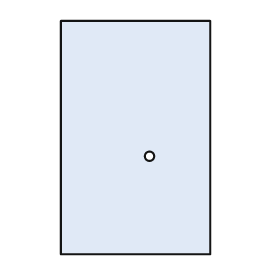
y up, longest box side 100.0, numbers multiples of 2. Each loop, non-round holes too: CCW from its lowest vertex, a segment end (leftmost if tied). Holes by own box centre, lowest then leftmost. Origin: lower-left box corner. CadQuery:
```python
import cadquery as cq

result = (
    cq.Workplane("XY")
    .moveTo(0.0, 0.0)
    .lineTo(64.0, 0.0)
    .lineTo(64.0, 100.0)
    .lineTo(0.0, 100.0)
    .close()
    .moveTo(38.0, 42.0)
    .circle(2.0)
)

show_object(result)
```